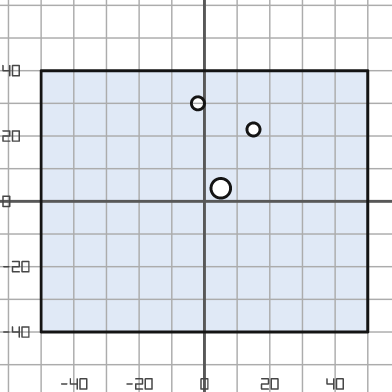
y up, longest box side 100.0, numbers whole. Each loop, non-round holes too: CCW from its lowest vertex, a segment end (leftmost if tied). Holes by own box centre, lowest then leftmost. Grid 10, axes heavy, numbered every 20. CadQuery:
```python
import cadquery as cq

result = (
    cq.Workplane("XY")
    .moveTo(-50.0, -40.0)
    .lineTo(50.0, -40.0)
    .lineTo(50.0, 40.0)
    .lineTo(-50.0, 40.0)
    .close()
    .moveTo(5.0, 4.0)
    .circle(3.0)
    .moveTo(15.0, 22.0)
    .circle(2.0)
    .moveTo(-2.0, 30.0)
    .circle(2.0)
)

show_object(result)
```